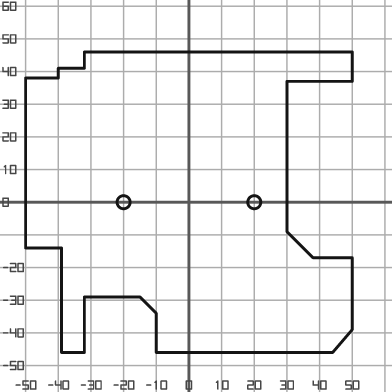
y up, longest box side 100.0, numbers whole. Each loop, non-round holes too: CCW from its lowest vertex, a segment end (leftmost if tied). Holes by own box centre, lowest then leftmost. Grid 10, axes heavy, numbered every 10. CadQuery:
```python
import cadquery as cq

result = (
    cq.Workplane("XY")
    .moveTo(-39.0, -46.0)
    .lineTo(-32.0, -46.0)
    .lineTo(-32.0, -29.0)
    .lineTo(-15.0, -29.0)
    .lineTo(-10.0, -34.0)
    .lineTo(-10.0, -46.0)
    .lineTo(44.0, -46.0)
    .lineTo(50.0, -39.0)
    .lineTo(50.0, -17.0)
    .lineTo(38.0, -17.0)
    .lineTo(30.0, -9.0)
    .lineTo(30.0, 37.0)
    .lineTo(50.0, 37.0)
    .lineTo(50.0, 46.0)
    .lineTo(-32.0, 46.0)
    .lineTo(-32.0, 41.0)
    .lineTo(-40.0, 41.0)
    .lineTo(-40.0, 38.0)
    .lineTo(-50.0, 38.0)
    .lineTo(-50.0, -14.0)
    .lineTo(-39.0, -14.0)
    .close()
    .moveTo(-20.0, 0.0)
    .circle(2.0)
    .moveTo(20.0, 0.0)
    .circle(2.0)
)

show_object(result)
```